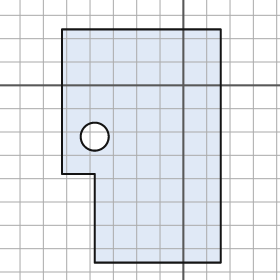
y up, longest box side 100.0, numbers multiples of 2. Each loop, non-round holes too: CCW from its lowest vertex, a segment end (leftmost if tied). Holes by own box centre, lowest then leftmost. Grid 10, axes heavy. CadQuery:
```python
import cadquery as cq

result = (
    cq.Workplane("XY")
    .moveTo(-38.0, -76.0)
    .lineTo(16.0, -76.0)
    .lineTo(16.0, 24.0)
    .lineTo(-52.0, 24.0)
    .lineTo(-52.0, -38.0)
    .lineTo(-38.0, -38.0)
    .close()
    .moveTo(-38.0, -22.0)
    .circle(6.0)
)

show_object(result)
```